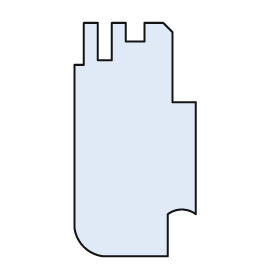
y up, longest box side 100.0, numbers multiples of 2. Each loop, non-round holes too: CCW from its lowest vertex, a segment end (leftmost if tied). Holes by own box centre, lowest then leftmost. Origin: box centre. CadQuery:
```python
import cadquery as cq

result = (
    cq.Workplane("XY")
    .moveTo(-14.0, -50.0)
    .lineTo(14.0, -50.0)
    .lineTo(14.0, -32.0)
    .threePointArc((20.0, -30.0), (26.0, -32.0))
    .lineTo(26.0, 16.0)
    .lineTo(16.0, 16.0)
    .lineTo(16.0, 46.0)
    .lineTo(12.0, 50.0)
    .lineTo(4.0, 50.0)
    .lineTo(4.0, 42.0)
    .lineTo(-4.0, 42.0)
    .lineTo(-4.0, 50.0)
    .lineTo(-10.0, 50.0)
    .lineTo(-10.0, 34.0)
    .lineTo(-16.0, 34.0)
    .lineTo(-16.0, 50.0)
    .lineTo(-22.0, 50.0)
    .lineTo(-22.0, 32.0)
    .lineTo(-26.0, 32.0)
    .lineTo(-26.0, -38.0)
    .threePointArc((-22.0, -46.0), (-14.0, -50.0))
    .close()
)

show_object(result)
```